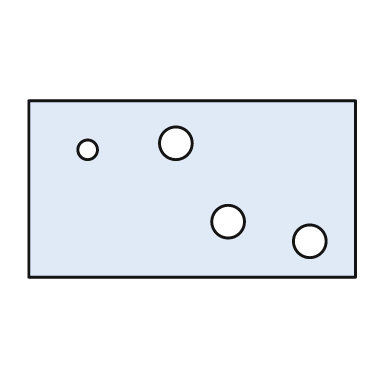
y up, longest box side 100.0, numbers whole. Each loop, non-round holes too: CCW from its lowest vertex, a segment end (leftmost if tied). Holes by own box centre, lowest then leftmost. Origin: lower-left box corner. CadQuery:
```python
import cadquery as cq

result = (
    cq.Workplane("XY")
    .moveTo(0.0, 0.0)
    .lineTo(100.0, 0.0)
    .lineTo(100.0, 54.0)
    .lineTo(0.0, 54.0)
    .close()
    .moveTo(86.0, 11.0)
    .circle(5.0)
    .moveTo(61.0, 17.0)
    .circle(5.0)
    .moveTo(18.0, 39.0)
    .circle(3.0)
    .moveTo(45.0, 41.0)
    .circle(5.0)
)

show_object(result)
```